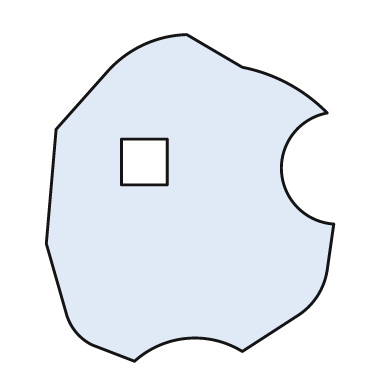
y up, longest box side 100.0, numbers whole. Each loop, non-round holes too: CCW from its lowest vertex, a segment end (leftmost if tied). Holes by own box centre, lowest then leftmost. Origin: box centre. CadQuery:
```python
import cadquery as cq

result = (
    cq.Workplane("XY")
    .moveTo(-17.0, -50.0)
    .threePointArc((-1.0, -43.0), (16.0, -47.0))
    .lineTo(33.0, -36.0)
    .threePointArc((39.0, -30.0), (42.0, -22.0))
    .lineTo(44.0, -8.0)
    .threePointArc((28.0, 8.0), (42.0, 26.0))
    .threePointArc((30.0, 35.0), (16.0, 40.0))
    .lineTo(-1.0, 50.0)
    .threePointArc((-14.0, 47.0), (-25.0, 39.0))
    .lineTo(-41.0, 21.0)
    .lineTo(-44.0, -14.0)
    .lineTo(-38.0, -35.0)
    .threePointArc((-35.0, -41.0), (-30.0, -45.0))
    .close()
    .moveTo(-21.0, 4.0)
    .lineTo(-7.0, 4.0)
    .lineTo(-7.0, 18.0)
    .lineTo(-21.0, 18.0)
    .close()
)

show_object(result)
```